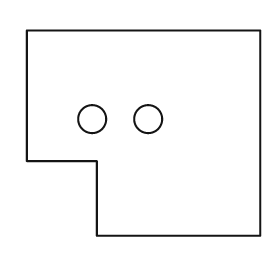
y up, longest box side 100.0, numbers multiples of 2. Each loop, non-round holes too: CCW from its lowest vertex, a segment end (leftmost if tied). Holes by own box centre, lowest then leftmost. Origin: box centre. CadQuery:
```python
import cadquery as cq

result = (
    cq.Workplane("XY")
    .moveTo(-20.0, -44.0)
    .lineTo(50.0, -44.0)
    .lineTo(50.0, 44.0)
    .lineTo(-50.0, 44.0)
    .lineTo(-50.0, -12.0)
    .lineTo(-20.0, -12.0)
    .close()
    .moveTo(-22.0, 6.0)
    .circle(6.0)
    .moveTo(2.0, 6.0)
    .circle(6.0)
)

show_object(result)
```